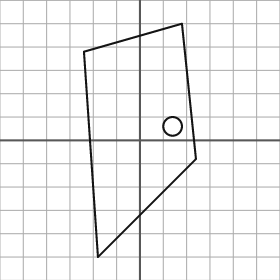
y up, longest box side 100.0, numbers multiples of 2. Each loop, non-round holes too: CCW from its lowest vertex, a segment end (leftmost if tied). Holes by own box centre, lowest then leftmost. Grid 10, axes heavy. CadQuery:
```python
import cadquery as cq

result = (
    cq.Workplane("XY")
    .moveTo(-18.0, -50.0)
    .lineTo(24.0, -8.0)
    .lineTo(18.0, 50.0)
    .lineTo(-24.0, 38.0)
    .close()
    .moveTo(14.0, 6.0)
    .circle(4.0)
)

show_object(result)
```